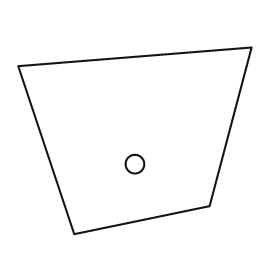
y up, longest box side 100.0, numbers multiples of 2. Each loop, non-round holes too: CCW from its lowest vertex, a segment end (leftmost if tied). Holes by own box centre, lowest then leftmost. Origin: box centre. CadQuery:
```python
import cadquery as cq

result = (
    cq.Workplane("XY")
    .moveTo(-26.0, -40.0)
    .lineTo(32.0, -28.0)
    .lineTo(50.0, 40.0)
    .lineTo(-50.0, 32.0)
    .close()
    .moveTo(0.0, -10.0)
    .circle(4.0)
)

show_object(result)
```